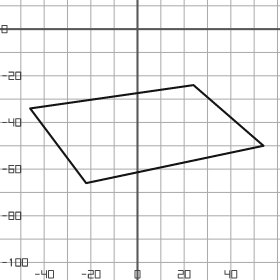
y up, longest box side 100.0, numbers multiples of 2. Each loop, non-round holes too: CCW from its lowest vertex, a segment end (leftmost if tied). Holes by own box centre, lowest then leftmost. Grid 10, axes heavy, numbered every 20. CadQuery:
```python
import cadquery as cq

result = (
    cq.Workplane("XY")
    .moveTo(-22.0, -66.0)
    .lineTo(54.0, -50.0)
    .lineTo(24.0, -24.0)
    .lineTo(-46.0, -34.0)
    .close()
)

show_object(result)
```